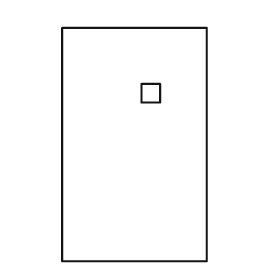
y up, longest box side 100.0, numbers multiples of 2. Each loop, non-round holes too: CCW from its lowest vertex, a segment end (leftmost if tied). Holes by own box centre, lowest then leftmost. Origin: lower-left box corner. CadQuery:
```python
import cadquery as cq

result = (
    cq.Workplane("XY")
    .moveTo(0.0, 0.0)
    .lineTo(62.0, 0.0)
    .lineTo(62.0, 100.0)
    .lineTo(0.0, 100.0)
    .close()
    .moveTo(34.0, 68.0)
    .lineTo(42.0, 68.0)
    .lineTo(42.0, 76.0)
    .lineTo(34.0, 76.0)
    .close()
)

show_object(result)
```